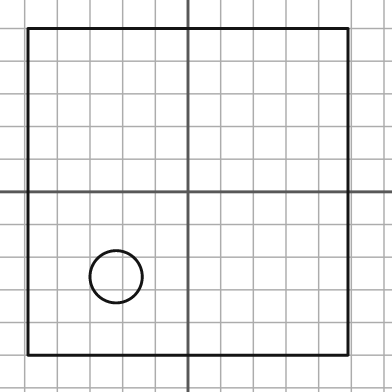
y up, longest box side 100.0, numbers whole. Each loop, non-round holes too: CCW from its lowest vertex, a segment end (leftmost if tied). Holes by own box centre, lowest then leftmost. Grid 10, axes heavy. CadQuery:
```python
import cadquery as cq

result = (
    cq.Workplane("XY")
    .moveTo(-49.0, -50.0)
    .lineTo(49.0, -50.0)
    .lineTo(49.0, 50.0)
    .lineTo(-49.0, 50.0)
    .close()
    .moveTo(-22.0, -26.0)
    .circle(8.0)
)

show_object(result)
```